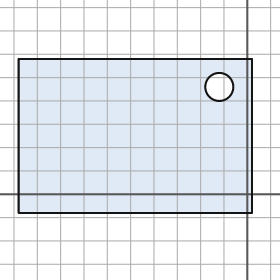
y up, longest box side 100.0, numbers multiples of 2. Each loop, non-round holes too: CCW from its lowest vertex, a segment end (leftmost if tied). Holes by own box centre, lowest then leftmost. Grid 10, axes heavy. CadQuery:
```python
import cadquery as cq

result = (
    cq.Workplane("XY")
    .moveTo(-98.0, -8.0)
    .lineTo(2.0, -8.0)
    .lineTo(2.0, 58.0)
    .lineTo(-98.0, 58.0)
    .close()
    .moveTo(-12.0, 46.0)
    .circle(6.0)
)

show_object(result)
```